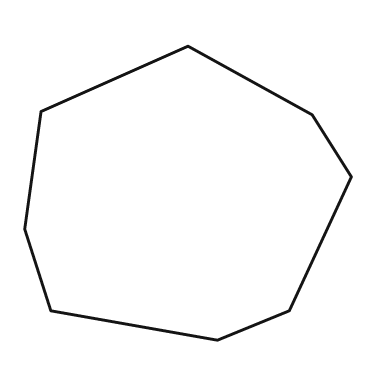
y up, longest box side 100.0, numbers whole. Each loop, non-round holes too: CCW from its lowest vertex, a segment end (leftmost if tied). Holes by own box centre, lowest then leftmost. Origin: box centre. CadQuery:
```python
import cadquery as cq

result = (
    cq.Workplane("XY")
    .moveTo(9.0, -45.0)
    .lineTo(31.0, -36.0)
    .lineTo(50.0, 5.0)
    .lineTo(38.0, 24.0)
    .lineTo(0.0, 45.0)
    .lineTo(-45.0, 25.0)
    .lineTo(-50.0, -11.0)
    .lineTo(-42.0, -36.0)
    .close()
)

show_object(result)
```